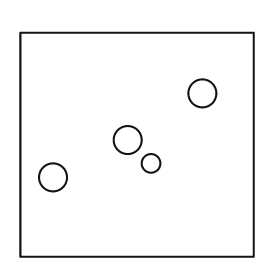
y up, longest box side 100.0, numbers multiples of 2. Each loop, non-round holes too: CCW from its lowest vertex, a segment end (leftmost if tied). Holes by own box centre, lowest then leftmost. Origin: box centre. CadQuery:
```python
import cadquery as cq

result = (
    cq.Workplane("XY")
    .moveTo(-50.0, -48.0)
    .lineTo(50.0, -48.0)
    .lineTo(50.0, 48.0)
    .lineTo(-50.0, 48.0)
    .close()
    .moveTo(-36.0, -14.0)
    .circle(6.0)
    .moveTo(6.0, -8.0)
    .circle(4.0)
    .moveTo(-4.0, 2.0)
    .circle(6.0)
    .moveTo(28.0, 22.0)
    .circle(6.0)
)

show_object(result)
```